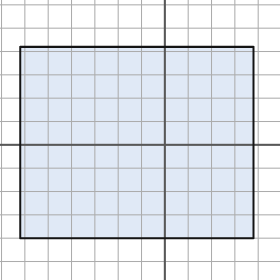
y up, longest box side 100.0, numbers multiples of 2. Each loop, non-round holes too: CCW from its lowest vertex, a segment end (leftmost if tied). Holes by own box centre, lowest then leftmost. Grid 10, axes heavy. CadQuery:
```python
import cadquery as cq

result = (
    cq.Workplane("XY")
    .moveTo(-62.0, -40.0)
    .lineTo(38.0, -40.0)
    .lineTo(38.0, 42.0)
    .lineTo(-62.0, 42.0)
    .close()
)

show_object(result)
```